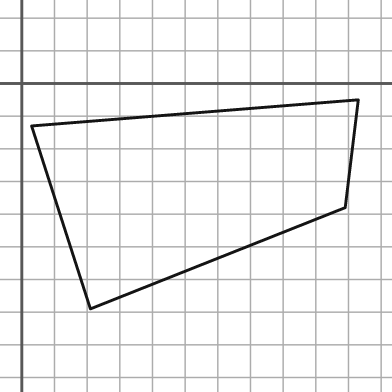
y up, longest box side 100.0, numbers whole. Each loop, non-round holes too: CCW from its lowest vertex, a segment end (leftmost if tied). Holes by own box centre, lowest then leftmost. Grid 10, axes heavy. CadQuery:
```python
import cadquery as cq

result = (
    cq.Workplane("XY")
    .moveTo(21.0, -69.0)
    .lineTo(99.0, -38.0)
    .lineTo(103.0, -5.0)
    .lineTo(3.0, -13.0)
    .close()
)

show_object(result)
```